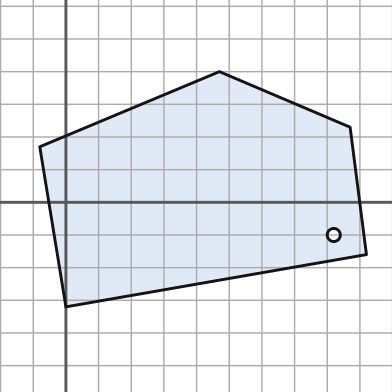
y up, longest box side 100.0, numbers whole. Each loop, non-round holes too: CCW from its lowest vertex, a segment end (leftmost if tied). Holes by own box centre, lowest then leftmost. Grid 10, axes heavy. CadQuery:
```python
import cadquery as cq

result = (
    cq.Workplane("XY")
    .moveTo(0.0, -32.0)
    .lineTo(92.0, -16.0)
    .lineTo(87.0, 23.0)
    .lineTo(47.0, 40.0)
    .lineTo(-8.0, 17.0)
    .close()
    .moveTo(82.0, -10.0)
    .circle(2.0)
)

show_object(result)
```